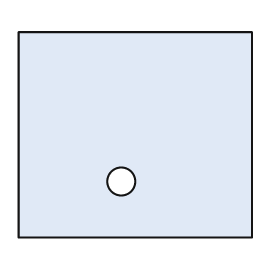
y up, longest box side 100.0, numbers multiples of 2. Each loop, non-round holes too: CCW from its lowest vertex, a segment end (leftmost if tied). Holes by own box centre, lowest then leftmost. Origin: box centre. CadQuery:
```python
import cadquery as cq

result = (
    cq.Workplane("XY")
    .moveTo(-50.0, -44.0)
    .lineTo(50.0, -44.0)
    .lineTo(50.0, 44.0)
    .lineTo(-50.0, 44.0)
    .close()
    .moveTo(-6.0, -20.0)
    .circle(6.0)
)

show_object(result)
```